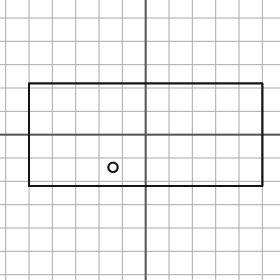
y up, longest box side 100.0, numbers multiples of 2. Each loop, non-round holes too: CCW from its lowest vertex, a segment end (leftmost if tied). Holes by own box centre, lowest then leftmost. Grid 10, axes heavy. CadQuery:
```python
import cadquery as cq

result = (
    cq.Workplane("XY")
    .moveTo(-50.0, -22.0)
    .lineTo(50.0, -22.0)
    .lineTo(50.0, 22.0)
    .lineTo(-50.0, 22.0)
    .close()
    .moveTo(-14.0, -14.0)
    .circle(2.0)
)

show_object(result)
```